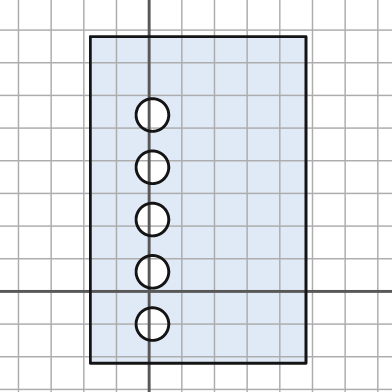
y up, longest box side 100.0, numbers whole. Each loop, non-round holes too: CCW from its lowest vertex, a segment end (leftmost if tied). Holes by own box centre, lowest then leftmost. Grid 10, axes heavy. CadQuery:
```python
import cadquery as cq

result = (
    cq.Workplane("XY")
    .moveTo(-18.0, -22.0)
    .lineTo(48.0, -22.0)
    .lineTo(48.0, 78.0)
    .lineTo(-18.0, 78.0)
    .close()
    .moveTo(1.0, -10.0)
    .circle(5.0)
    .moveTo(1.0, 6.0)
    .circle(5.0)
    .moveTo(1.0, 22.0)
    .circle(5.0)
    .moveTo(1.0, 38.0)
    .circle(5.0)
    .moveTo(1.0, 54.0)
    .circle(5.0)
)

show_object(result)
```